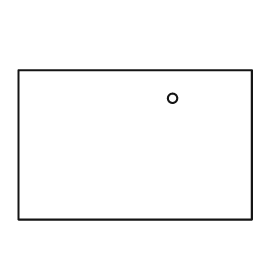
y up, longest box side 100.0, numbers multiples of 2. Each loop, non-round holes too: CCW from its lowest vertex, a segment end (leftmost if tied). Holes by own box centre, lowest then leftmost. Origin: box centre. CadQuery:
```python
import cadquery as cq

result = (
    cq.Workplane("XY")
    .moveTo(-50.0, -32.0)
    .lineTo(50.0, -32.0)
    .lineTo(50.0, 32.0)
    .lineTo(-50.0, 32.0)
    .close()
    .moveTo(16.0, 20.0)
    .circle(2.0)
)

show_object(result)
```